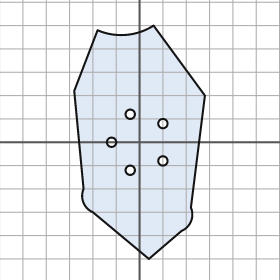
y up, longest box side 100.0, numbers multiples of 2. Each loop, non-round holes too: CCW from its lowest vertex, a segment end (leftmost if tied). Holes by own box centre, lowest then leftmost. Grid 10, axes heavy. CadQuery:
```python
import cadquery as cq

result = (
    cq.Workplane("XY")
    .moveTo(4.0, -50.0)
    .lineTo(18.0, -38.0)
    .threePointArc((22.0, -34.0), (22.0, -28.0))
    .lineTo(28.0, 20.0)
    .lineTo(6.0, 50.0)
    .threePointArc((-6.0, 46.0), (-18.0, 48.0))
    .lineTo(-28.0, 22.0)
    .lineTo(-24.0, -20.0)
    .threePointArc((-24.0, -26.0), (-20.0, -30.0))
    .close()
    .moveTo(-4.0, -12.0)
    .circle(2.0)
    .moveTo(10.0, -8.0)
    .circle(2.0)
    .moveTo(-12.0, 0.0)
    .circle(2.0)
    .moveTo(10.0, 8.0)
    .circle(2.0)
    .moveTo(-4.0, 12.0)
    .circle(2.0)
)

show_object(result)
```